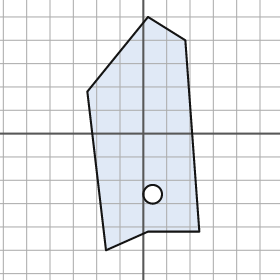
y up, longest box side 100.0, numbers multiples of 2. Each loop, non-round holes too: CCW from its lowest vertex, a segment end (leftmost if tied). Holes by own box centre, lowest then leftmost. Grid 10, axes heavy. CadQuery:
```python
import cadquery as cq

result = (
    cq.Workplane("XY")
    .moveTo(-16.0, -50.0)
    .lineTo(2.0, -42.0)
    .lineTo(24.0, -42.0)
    .lineTo(18.0, 40.0)
    .lineTo(2.0, 50.0)
    .lineTo(-24.0, 18.0)
    .close()
    .moveTo(4.0, -26.0)
    .circle(4.0)
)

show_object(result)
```